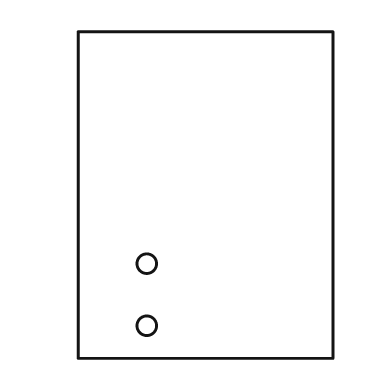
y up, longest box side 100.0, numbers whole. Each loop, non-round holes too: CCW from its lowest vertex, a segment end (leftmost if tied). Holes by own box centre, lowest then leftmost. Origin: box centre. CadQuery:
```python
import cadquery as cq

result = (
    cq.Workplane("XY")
    .moveTo(-39.0, -50.0)
    .lineTo(39.0, -50.0)
    .lineTo(39.0, 50.0)
    .lineTo(-39.0, 50.0)
    .close()
    .moveTo(-18.0, -40.0)
    .circle(3.0)
    .moveTo(-18.0, -21.0)
    .circle(3.0)
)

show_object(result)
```